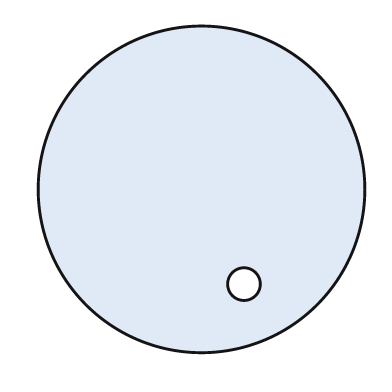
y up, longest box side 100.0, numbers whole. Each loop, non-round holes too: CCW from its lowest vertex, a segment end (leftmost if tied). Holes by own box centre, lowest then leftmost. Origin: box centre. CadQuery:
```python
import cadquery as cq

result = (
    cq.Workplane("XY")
    .moveTo(0.0, 0.0)
    .circle(50.0)
    .moveTo(13.0, -29.0)
    .circle(5.0)
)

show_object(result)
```